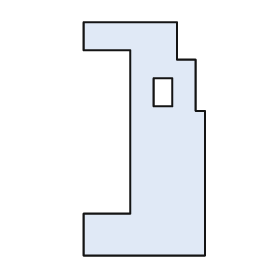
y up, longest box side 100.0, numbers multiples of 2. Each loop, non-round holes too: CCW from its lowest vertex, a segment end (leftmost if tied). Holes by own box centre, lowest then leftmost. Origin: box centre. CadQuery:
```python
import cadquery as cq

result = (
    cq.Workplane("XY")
    .moveTo(-26.0, -50.0)
    .lineTo(26.0, -50.0)
    .lineTo(26.0, 12.0)
    .lineTo(22.0, 12.0)
    .lineTo(22.0, 34.0)
    .lineTo(14.0, 34.0)
    .lineTo(14.0, 50.0)
    .lineTo(-26.0, 50.0)
    .lineTo(-26.0, 38.0)
    .lineTo(-6.0, 38.0)
    .lineTo(-6.0, -32.0)
    .lineTo(-26.0, -32.0)
    .close()
    .moveTo(4.0, 14.0)
    .lineTo(12.0, 14.0)
    .lineTo(12.0, 26.0)
    .lineTo(4.0, 26.0)
    .close()
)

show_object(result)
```